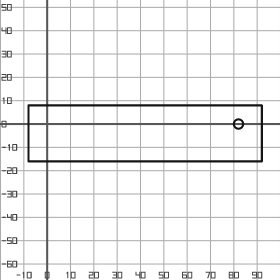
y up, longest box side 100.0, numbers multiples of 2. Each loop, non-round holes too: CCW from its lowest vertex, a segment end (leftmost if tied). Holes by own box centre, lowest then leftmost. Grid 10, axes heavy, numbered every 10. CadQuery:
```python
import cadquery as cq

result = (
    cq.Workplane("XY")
    .moveTo(-8.0, -16.0)
    .lineTo(92.0, -16.0)
    .lineTo(92.0, 8.0)
    .lineTo(-8.0, 8.0)
    .close()
    .moveTo(82.0, 0.0)
    .circle(2.0)
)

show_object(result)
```